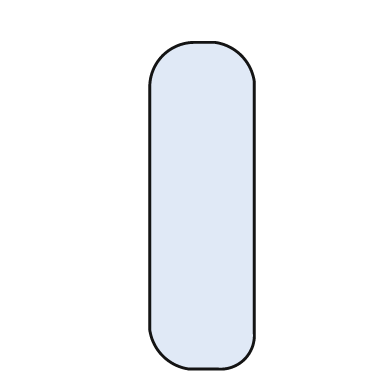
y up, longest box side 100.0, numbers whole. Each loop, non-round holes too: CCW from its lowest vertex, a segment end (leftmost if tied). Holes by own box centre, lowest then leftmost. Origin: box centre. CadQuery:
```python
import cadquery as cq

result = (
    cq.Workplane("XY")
    .moveTo(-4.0, -50.0)
    .lineTo(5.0, -50.0)
    .threePointArc((13.0, -47.0), (16.0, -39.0))
    .lineTo(16.0, 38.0)
    .threePointArc((12.0, 46.0), (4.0, 50.0))
    .lineTo(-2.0, 50.0)
    .threePointArc((-12.0, 46.0), (-16.0, 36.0))
    .lineTo(-16.0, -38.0)
    .threePointArc((-12.0, -46.0), (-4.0, -50.0))
    .close()
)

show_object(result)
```